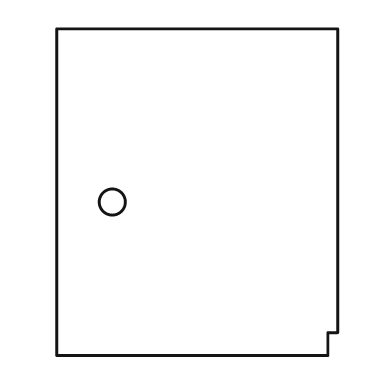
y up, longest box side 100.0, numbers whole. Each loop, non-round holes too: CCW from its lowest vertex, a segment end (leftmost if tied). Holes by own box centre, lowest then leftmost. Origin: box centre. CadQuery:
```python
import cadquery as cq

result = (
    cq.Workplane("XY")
    .moveTo(-43.0, -50.0)
    .lineTo(40.0, -50.0)
    .lineTo(40.0, -43.0)
    .lineTo(43.0, -43.0)
    .lineTo(43.0, 50.0)
    .lineTo(-43.0, 50.0)
    .close()
    .moveTo(-26.0, -3.0)
    .circle(4.0)
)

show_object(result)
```